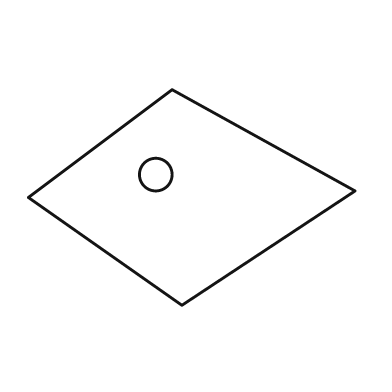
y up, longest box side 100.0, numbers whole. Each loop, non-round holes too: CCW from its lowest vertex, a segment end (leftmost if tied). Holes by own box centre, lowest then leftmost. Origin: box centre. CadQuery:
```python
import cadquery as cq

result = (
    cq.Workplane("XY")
    .moveTo(-3.0, -33.0)
    .lineTo(50.0, 2.0)
    .lineTo(-6.0, 33.0)
    .lineTo(-50.0, 0.0)
    .close()
    .moveTo(-11.0, 7.0)
    .circle(5.0)
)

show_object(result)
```